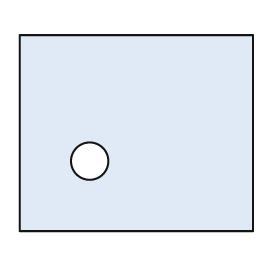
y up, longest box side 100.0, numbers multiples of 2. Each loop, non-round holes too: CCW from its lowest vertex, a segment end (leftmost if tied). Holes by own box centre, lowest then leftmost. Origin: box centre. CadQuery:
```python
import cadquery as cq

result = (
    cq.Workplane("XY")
    .moveTo(-50.0, -42.0)
    .lineTo(50.0, -42.0)
    .lineTo(50.0, 42.0)
    .lineTo(-50.0, 42.0)
    .close()
    .moveTo(-20.0, -12.0)
    .circle(8.0)
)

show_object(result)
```